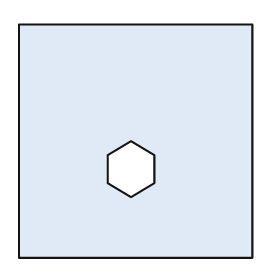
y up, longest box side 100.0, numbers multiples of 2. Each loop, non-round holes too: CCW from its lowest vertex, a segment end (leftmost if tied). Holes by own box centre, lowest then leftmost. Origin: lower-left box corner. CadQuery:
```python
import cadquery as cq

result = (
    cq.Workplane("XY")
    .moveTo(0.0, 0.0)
    .lineTo(100.0, 0.0)
    .lineTo(100.0, 100.0)
    .lineTo(0.0, 100.0)
    .close()
    .moveTo(48.0, 26.0)
    .lineTo(58.0, 32.0)
    .lineTo(58.0, 44.0)
    .lineTo(48.0, 50.0)
    .lineTo(38.0, 44.0)
    .lineTo(38.0, 32.0)
    .close()
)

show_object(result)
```